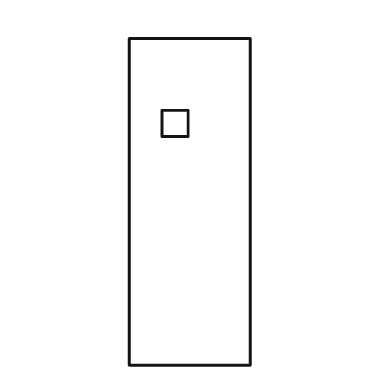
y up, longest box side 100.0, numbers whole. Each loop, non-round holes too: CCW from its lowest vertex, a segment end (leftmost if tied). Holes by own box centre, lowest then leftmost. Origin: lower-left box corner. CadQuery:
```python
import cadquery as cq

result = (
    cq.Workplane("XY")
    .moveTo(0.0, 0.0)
    .lineTo(37.0, 0.0)
    .lineTo(37.0, 100.0)
    .lineTo(0.0, 100.0)
    .close()
    .moveTo(10.0, 70.0)
    .lineTo(18.0, 70.0)
    .lineTo(18.0, 78.0)
    .lineTo(10.0, 78.0)
    .close()
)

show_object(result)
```